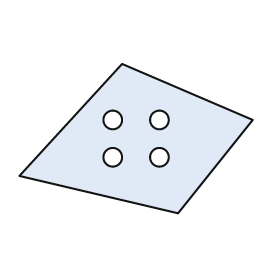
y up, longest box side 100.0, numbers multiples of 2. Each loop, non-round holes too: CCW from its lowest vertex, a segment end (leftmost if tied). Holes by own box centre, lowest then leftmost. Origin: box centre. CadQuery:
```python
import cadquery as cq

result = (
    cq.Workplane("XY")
    .moveTo(18.0, -32.0)
    .lineTo(50.0, 8.0)
    .lineTo(-6.0, 32.0)
    .lineTo(-50.0, -16.0)
    .close()
    .moveTo(-10.0, -8.0)
    .circle(4.0)
    .moveTo(10.0, -8.0)
    .circle(4.0)
    .moveTo(-10.0, 8.0)
    .circle(4.0)
    .moveTo(10.0, 8.0)
    .circle(4.0)
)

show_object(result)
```